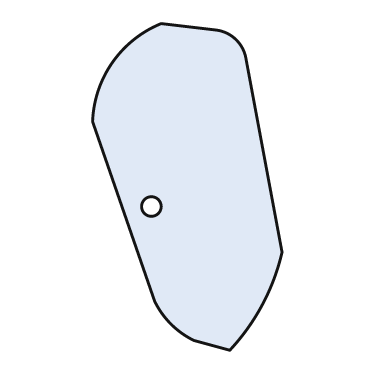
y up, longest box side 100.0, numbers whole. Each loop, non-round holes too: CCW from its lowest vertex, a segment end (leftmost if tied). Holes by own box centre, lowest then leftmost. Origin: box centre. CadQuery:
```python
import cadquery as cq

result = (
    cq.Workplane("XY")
    .moveTo(13.0, -50.0)
    .threePointArc((23.0, -36.0), (29.0, -20.0))
    .lineTo(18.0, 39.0)
    .threePointArc((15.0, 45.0), (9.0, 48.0))
    .lineTo(-8.0, 50.0)
    .threePointArc((-23.0, 38.0), (-29.0, 20.0))
    .lineTo(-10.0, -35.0)
    .threePointArc((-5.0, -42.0), (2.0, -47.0))
    .close()
    .moveTo(-11.0, -6.0)
    .circle(3.0)
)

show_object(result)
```